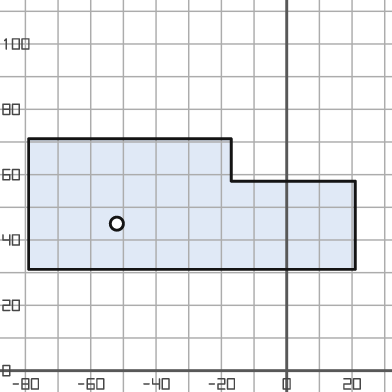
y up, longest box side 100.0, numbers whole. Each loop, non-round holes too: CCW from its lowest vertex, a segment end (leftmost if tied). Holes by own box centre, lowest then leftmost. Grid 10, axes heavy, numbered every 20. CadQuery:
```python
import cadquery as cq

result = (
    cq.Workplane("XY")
    .moveTo(-79.0, 31.0)
    .lineTo(21.0, 31.0)
    .lineTo(21.0, 58.0)
    .lineTo(-17.0, 58.0)
    .lineTo(-17.0, 71.0)
    .lineTo(-79.0, 71.0)
    .close()
    .moveTo(-52.0, 45.0)
    .circle(2.0)
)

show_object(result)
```